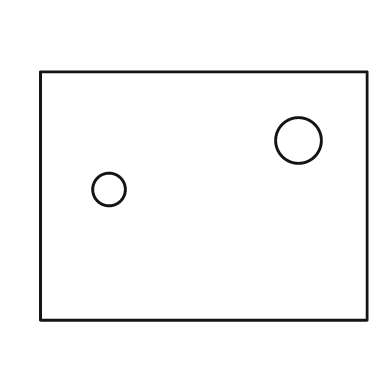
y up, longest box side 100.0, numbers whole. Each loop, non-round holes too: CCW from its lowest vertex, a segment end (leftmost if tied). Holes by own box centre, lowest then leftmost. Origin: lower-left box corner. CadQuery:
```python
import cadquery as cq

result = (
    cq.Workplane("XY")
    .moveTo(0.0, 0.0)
    .lineTo(100.0, 0.0)
    .lineTo(100.0, 76.0)
    .lineTo(0.0, 76.0)
    .close()
    .moveTo(21.0, 40.0)
    .circle(5.0)
    .moveTo(79.0, 55.0)
    .circle(7.0)
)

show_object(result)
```